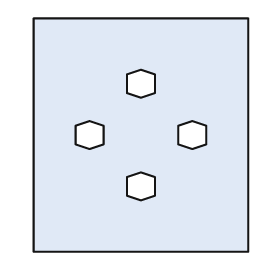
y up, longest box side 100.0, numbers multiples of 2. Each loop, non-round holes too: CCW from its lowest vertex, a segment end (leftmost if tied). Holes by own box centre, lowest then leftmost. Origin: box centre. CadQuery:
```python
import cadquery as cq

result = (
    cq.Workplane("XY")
    .moveTo(-46.0, -50.0)
    .lineTo(46.0, -50.0)
    .lineTo(46.0, 50.0)
    .lineTo(-46.0, 50.0)
    .close()
    .moveTo(0.0, -28.0)
    .lineTo(6.0, -26.0)
    .lineTo(6.0, -18.0)
    .lineTo(0.0, -16.0)
    .lineTo(-6.0, -18.0)
    .lineTo(-6.0, -26.0)
    .close()
    .moveTo(-22.0, -6.0)
    .lineTo(-16.0, -4.0)
    .lineTo(-16.0, 4.0)
    .lineTo(-22.0, 6.0)
    .lineTo(-28.0, 4.0)
    .lineTo(-28.0, -4.0)
    .close()
    .moveTo(22.0, -6.0)
    .lineTo(28.0, -4.0)
    .lineTo(28.0, 4.0)
    .lineTo(22.0, 6.0)
    .lineTo(16.0, 4.0)
    .lineTo(16.0, -4.0)
    .close()
    .moveTo(0.0, 16.0)
    .lineTo(6.0, 18.0)
    .lineTo(6.0, 26.0)
    .lineTo(0.0, 28.0)
    .lineTo(-6.0, 26.0)
    .lineTo(-6.0, 18.0)
    .close()
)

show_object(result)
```